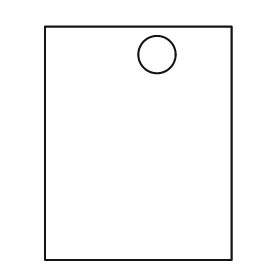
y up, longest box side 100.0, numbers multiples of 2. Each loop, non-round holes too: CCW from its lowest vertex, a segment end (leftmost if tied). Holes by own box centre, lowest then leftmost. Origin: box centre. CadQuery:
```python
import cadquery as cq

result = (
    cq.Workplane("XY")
    .moveTo(-40.0, -50.0)
    .lineTo(40.0, -50.0)
    .lineTo(40.0, 50.0)
    .lineTo(-40.0, 50.0)
    .close()
    .moveTo(8.0, 38.0)
    .circle(8.0)
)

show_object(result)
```